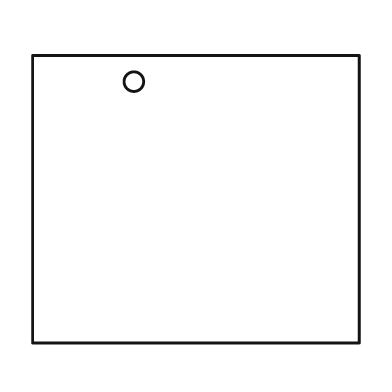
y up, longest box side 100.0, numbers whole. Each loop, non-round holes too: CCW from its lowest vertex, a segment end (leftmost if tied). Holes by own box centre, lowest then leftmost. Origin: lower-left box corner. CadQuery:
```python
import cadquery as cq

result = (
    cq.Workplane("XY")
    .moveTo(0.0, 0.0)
    .lineTo(100.0, 0.0)
    .lineTo(100.0, 88.0)
    .lineTo(0.0, 88.0)
    .close()
    .moveTo(31.0, 80.0)
    .circle(3.0)
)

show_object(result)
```